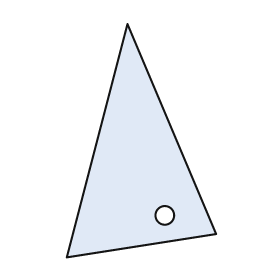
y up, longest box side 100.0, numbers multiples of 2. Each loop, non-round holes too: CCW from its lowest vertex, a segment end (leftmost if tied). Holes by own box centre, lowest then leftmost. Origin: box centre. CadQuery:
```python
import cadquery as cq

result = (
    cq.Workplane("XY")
    .moveTo(-32.0, -50.0)
    .lineTo(32.0, -40.0)
    .lineTo(-6.0, 50.0)
    .close()
    .moveTo(10.0, -32.0)
    .circle(4.0)
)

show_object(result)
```